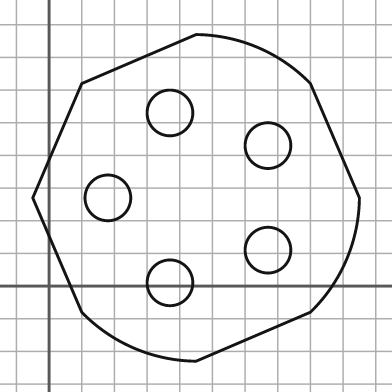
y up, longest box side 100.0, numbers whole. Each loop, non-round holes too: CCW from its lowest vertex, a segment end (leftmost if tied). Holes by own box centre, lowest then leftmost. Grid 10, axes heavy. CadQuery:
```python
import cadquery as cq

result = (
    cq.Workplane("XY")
    .moveTo(45.0, -23.0)
    .lineTo(80.0, -8.0)
    .threePointArc((91.0, 8.0), (95.0, 27.0))
    .lineTo(80.0, 62.0)
    .threePointArc((64.0, 73.0), (45.0, 77.0))
    .lineTo(10.0, 62.0)
    .lineTo(-5.0, 27.0)
    .lineTo(10.0, -8.0)
    .threePointArc((26.0, -19.0), (45.0, -23.0))
    .close()
    .moveTo(37.0, 1.0)
    .circle(7.0)
    .moveTo(67.0, 11.0)
    .circle(7.0)
    .moveTo(18.0, 27.0)
    .circle(7.0)
    .moveTo(67.0, 43.0)
    .circle(7.0)
    .moveTo(37.0, 53.0)
    .circle(7.0)
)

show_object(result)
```